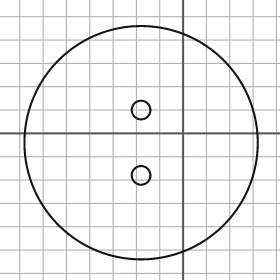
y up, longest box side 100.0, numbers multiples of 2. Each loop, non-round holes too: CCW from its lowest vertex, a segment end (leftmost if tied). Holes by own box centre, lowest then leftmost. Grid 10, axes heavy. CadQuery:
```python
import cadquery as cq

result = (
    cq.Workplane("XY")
    .moveTo(-18.0, -4.0)
    .circle(50.0)
    .moveTo(-18.0, -18.0)
    .circle(4.0)
    .moveTo(-18.0, 10.0)
    .circle(4.0)
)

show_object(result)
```